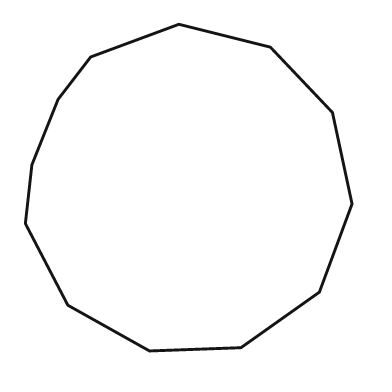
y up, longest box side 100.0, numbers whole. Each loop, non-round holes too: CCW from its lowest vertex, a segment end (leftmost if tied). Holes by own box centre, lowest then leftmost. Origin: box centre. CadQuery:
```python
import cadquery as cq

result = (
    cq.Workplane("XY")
    .moveTo(-12.0, -50.0)
    .lineTo(16.0, -49.0)
    .lineTo(40.0, -32.0)
    .lineTo(50.0, -5.0)
    .lineTo(44.0, 23.0)
    .lineTo(25.0, 43.0)
    .lineTo(-3.0, 50.0)
    .lineTo(-30.0, 40.0)
    .lineTo(-40.0, 27.0)
    .lineTo(-48.0, 7.0)
    .lineTo(-50.0, -11.0)
    .lineTo(-37.0, -36.0)
    .close()
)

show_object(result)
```